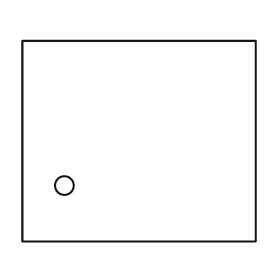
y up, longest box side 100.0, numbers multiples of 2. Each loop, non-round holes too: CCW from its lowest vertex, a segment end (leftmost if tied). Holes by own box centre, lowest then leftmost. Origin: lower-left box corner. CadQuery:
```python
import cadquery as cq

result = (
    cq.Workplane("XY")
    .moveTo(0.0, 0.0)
    .lineTo(100.0, 0.0)
    .lineTo(100.0, 86.0)
    .lineTo(0.0, 86.0)
    .close()
    .moveTo(18.0, 24.0)
    .circle(4.0)
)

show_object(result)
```